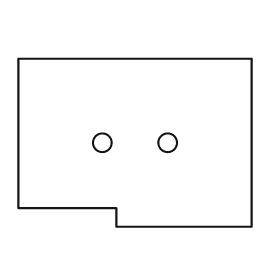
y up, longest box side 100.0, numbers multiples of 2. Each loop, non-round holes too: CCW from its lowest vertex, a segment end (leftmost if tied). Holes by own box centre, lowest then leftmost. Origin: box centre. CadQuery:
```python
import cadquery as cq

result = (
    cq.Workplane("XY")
    .moveTo(-8.0, -36.0)
    .lineTo(50.0, -36.0)
    .lineTo(50.0, 36.0)
    .lineTo(-50.0, 36.0)
    .lineTo(-50.0, -28.0)
    .lineTo(-8.0, -28.0)
    .close()
    .moveTo(-14.0, 0.0)
    .circle(4.0)
    .moveTo(14.0, 0.0)
    .circle(4.0)
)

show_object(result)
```